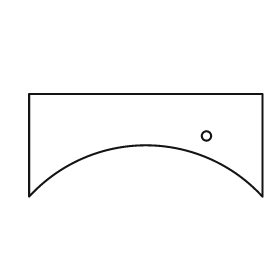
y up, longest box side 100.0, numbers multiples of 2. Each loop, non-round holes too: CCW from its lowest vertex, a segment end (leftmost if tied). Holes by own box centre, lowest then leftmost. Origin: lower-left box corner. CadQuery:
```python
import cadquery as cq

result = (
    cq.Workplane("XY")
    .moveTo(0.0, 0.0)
    .threePointArc((50.0, 22.0), (100.0, 0.0))
    .lineTo(100.0, 44.0)
    .lineTo(0.0, 44.0)
    .close()
    .moveTo(76.0, 26.0)
    .circle(2.0)
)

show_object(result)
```